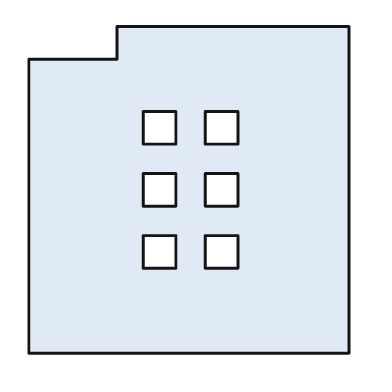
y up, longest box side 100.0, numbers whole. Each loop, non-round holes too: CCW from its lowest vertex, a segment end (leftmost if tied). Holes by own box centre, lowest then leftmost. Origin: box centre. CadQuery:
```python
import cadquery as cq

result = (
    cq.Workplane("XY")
    .moveTo(-49.0, -50.0)
    .lineTo(49.0, -50.0)
    .lineTo(49.0, 50.0)
    .lineTo(-22.0, 50.0)
    .lineTo(-22.0, 40.0)
    .lineTo(-49.0, 40.0)
    .close()
    .moveTo(-14.0, -24.0)
    .lineTo(-4.0, -24.0)
    .lineTo(-4.0, -14.0)
    .lineTo(-14.0, -14.0)
    .close()
    .moveTo(5.0, -24.0)
    .lineTo(15.0, -24.0)
    .lineTo(15.0, -14.0)
    .lineTo(5.0, -14.0)
    .close()
    .moveTo(-14.0, -5.0)
    .lineTo(-4.0, -5.0)
    .lineTo(-4.0, 5.0)
    .lineTo(-14.0, 5.0)
    .close()
    .moveTo(5.0, -5.0)
    .lineTo(15.0, -5.0)
    .lineTo(15.0, 5.0)
    .lineTo(5.0, 5.0)
    .close()
    .moveTo(-14.0, 14.0)
    .lineTo(-4.0, 14.0)
    .lineTo(-4.0, 24.0)
    .lineTo(-14.0, 24.0)
    .close()
    .moveTo(5.0, 14.0)
    .lineTo(15.0, 14.0)
    .lineTo(15.0, 24.0)
    .lineTo(5.0, 24.0)
    .close()
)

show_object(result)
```